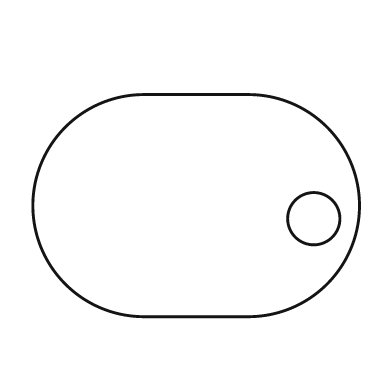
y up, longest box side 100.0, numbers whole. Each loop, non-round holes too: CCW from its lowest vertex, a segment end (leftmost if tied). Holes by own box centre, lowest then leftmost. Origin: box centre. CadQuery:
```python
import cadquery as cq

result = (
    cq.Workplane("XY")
    .moveTo(-16.0, -34.0)
    .lineTo(16.0, -34.0)
    .threePointArc((50.0, 0.0), (16.0, 34.0))
    .lineTo(-16.0, 34.0)
    .threePointArc((-50.0, 0.0), (-16.0, -34.0))
    .close()
    .moveTo(36.0, -4.0)
    .circle(8.0)
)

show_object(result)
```